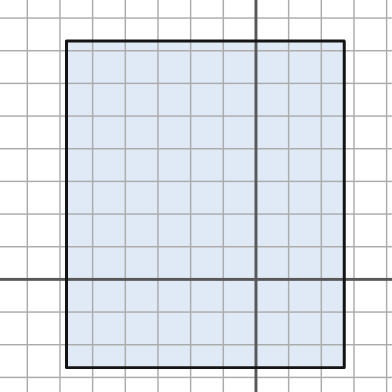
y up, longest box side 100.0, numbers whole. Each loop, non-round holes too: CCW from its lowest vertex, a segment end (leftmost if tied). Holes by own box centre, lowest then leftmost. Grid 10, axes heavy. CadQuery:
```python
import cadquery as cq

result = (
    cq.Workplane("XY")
    .moveTo(-58.0, -27.0)
    .lineTo(27.0, -27.0)
    .lineTo(27.0, 73.0)
    .lineTo(-58.0, 73.0)
    .close()
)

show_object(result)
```